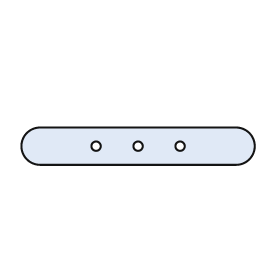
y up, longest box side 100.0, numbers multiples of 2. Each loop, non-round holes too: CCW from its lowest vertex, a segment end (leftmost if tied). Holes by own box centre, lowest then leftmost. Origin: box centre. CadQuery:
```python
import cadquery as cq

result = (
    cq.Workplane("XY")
    .moveTo(-42.0, -8.0)
    .lineTo(42.0, -8.0)
    .threePointArc((50.0, 0.0), (42.0, 8.0))
    .lineTo(-42.0, 8.0)
    .threePointArc((-50.0, 0.0), (-42.0, -8.0))
    .close()
    .moveTo(-18.0, 0.0)
    .circle(2.0)
    .moveTo(0.0, 0.0)
    .circle(2.0)
    .moveTo(18.0, 0.0)
    .circle(2.0)
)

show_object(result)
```